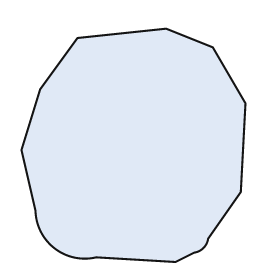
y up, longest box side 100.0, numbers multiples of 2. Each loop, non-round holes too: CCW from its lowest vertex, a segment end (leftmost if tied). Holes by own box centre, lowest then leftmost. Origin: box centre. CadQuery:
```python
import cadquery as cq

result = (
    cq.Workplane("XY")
    .moveTo(18.0, -50.0)
    .lineTo(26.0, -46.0)
    .threePointArc((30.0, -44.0), (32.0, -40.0))
    .lineTo(46.0, -20.0)
    .lineTo(48.0, 18.0)
    .lineTo(34.0, 42.0)
    .lineTo(14.0, 50.0)
    .lineTo(-24.0, 46.0)
    .lineTo(-40.0, 24.0)
    .lineTo(-48.0, -2.0)
    .lineTo(-42.0, -28.0)
    .threePointArc((-34.0, -44.0), (-16.0, -48.0))
    .close()
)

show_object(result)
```